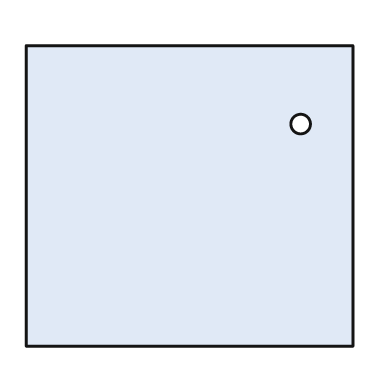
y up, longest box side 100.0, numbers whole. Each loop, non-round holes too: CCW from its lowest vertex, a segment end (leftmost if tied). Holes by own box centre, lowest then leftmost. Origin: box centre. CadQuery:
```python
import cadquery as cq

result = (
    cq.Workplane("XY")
    .moveTo(-50.0, -46.0)
    .lineTo(50.0, -46.0)
    .lineTo(50.0, 46.0)
    .lineTo(-50.0, 46.0)
    .close()
    .moveTo(34.0, 22.0)
    .circle(3.0)
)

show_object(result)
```